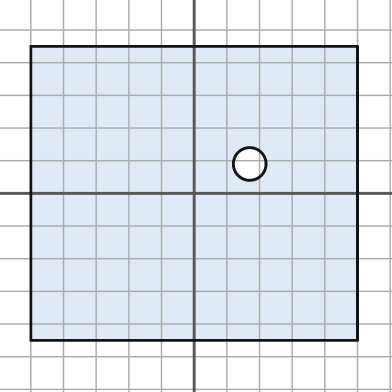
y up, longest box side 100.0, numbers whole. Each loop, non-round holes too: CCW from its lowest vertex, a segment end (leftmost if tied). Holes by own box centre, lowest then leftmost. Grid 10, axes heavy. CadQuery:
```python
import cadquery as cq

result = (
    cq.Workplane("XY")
    .moveTo(-50.0, -45.0)
    .lineTo(50.0, -45.0)
    .lineTo(50.0, 45.0)
    .lineTo(-50.0, 45.0)
    .close()
    .moveTo(17.0, 9.0)
    .circle(5.0)
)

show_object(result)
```